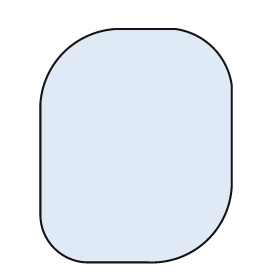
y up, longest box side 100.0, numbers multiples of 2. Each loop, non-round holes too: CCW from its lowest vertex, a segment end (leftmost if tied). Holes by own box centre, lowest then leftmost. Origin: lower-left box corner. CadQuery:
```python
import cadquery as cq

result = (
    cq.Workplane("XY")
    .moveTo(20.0, 0.0)
    .lineTo(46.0, 0.0)
    .threePointArc((72.0, 10.0), (82.0, 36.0))
    .lineTo(82.0, 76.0)
    .threePointArc((74.0, 92.0), (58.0, 100.0))
    .lineTo(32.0, 100.0)
    .threePointArc((10.0, 90.0), (0.0, 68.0))
    .lineTo(0.0, 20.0)
    .threePointArc((6.0, 6.0), (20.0, 0.0))
    .close()
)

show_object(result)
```